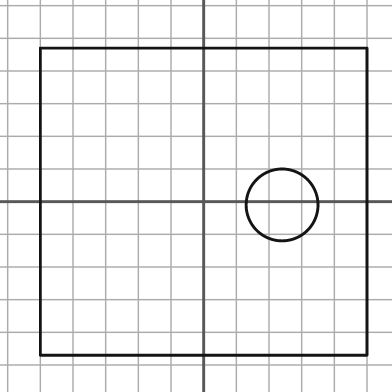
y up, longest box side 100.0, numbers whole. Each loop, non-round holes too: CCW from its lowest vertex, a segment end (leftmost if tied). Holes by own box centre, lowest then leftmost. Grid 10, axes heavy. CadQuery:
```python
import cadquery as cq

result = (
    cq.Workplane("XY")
    .moveTo(-50.0, -47.0)
    .lineTo(50.0, -47.0)
    .lineTo(50.0, 47.0)
    .lineTo(-50.0, 47.0)
    .close()
    .moveTo(24.0, -1.0)
    .circle(11.0)
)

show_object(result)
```